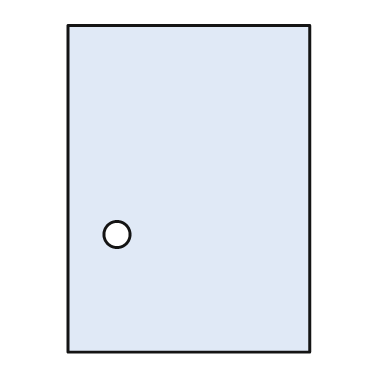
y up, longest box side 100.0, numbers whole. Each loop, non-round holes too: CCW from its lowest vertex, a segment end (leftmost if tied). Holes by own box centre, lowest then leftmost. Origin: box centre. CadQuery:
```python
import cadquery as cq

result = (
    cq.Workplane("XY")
    .moveTo(-37.0, -50.0)
    .lineTo(37.0, -50.0)
    .lineTo(37.0, 50.0)
    .lineTo(-37.0, 50.0)
    .close()
    .moveTo(-22.0, -14.0)
    .circle(4.0)
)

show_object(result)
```